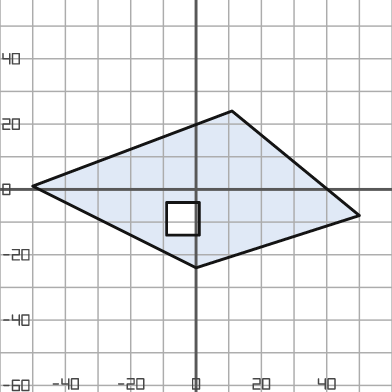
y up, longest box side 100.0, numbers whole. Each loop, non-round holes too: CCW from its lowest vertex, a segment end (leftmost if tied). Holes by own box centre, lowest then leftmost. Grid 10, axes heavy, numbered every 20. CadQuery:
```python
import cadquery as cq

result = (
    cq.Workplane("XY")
    .moveTo(0.0, -24.0)
    .lineTo(50.0, -8.0)
    .lineTo(11.0, 24.0)
    .lineTo(-50.0, 1.0)
    .close()
    .moveTo(-9.0, -14.0)
    .lineTo(1.0, -14.0)
    .lineTo(1.0, -4.0)
    .lineTo(-9.0, -4.0)
    .close()
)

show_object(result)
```